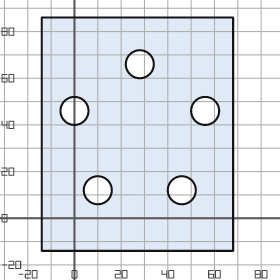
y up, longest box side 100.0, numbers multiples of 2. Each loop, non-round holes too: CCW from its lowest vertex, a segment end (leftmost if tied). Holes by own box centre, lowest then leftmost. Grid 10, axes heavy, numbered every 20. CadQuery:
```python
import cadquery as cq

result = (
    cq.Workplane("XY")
    .moveTo(-14.0, -14.0)
    .lineTo(68.0, -14.0)
    .lineTo(68.0, 86.0)
    .lineTo(-14.0, 86.0)
    .close()
    .moveTo(10.0, 12.0)
    .circle(6.0)
    .moveTo(46.0, 12.0)
    .circle(6.0)
    .moveTo(0.0, 46.0)
    .circle(6.0)
    .moveTo(56.0, 46.0)
    .circle(6.0)
    .moveTo(28.0, 66.0)
    .circle(6.0)
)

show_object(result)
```